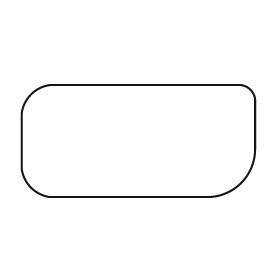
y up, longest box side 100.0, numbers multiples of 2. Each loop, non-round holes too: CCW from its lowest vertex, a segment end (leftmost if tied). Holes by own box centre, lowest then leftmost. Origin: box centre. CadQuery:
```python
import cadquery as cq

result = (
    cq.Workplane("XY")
    .moveTo(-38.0, -24.0)
    .lineTo(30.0, -24.0)
    .threePointArc((44.0, -18.0), (50.0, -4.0))
    .lineTo(50.0, 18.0)
    .threePointArc((48.0, 22.0), (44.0, 24.0))
    .lineTo(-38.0, 24.0)
    .threePointArc((-46.0, 20.0), (-50.0, 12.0))
    .lineTo(-50.0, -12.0)
    .threePointArc((-46.0, -20.0), (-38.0, -24.0))
    .close()
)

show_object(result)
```